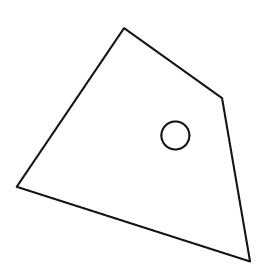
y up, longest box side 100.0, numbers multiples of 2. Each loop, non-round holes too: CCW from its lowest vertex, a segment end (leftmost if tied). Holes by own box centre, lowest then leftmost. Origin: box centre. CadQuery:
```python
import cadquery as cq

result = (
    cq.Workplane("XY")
    .moveTo(50.0, -50.0)
    .lineTo(38.0, 20.0)
    .lineTo(-4.0, 50.0)
    .lineTo(-50.0, -18.0)
    .close()
    .moveTo(18.0, 4.0)
    .circle(6.0)
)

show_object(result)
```